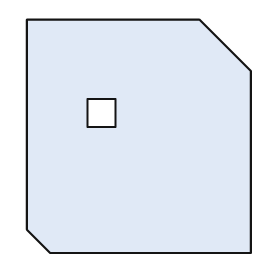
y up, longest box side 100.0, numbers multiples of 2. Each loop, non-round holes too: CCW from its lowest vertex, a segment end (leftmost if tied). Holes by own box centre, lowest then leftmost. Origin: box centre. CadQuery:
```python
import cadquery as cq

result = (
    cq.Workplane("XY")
    .moveTo(-38.0, -50.0)
    .lineTo(48.0, -50.0)
    .lineTo(48.0, 28.0)
    .lineTo(26.0, 50.0)
    .lineTo(-48.0, 50.0)
    .lineTo(-48.0, -40.0)
    .close()
    .moveTo(-22.0, 4.0)
    .lineTo(-10.0, 4.0)
    .lineTo(-10.0, 16.0)
    .lineTo(-22.0, 16.0)
    .close()
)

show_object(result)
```